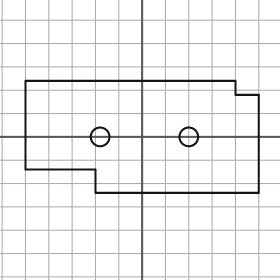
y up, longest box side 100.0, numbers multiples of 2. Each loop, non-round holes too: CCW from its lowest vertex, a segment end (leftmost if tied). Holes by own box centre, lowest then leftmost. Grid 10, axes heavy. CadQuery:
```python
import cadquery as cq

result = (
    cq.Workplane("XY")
    .moveTo(-20.0, -24.0)
    .lineTo(50.0, -24.0)
    .lineTo(50.0, 18.0)
    .lineTo(40.0, 18.0)
    .lineTo(40.0, 24.0)
    .lineTo(-50.0, 24.0)
    .lineTo(-50.0, -14.0)
    .lineTo(-20.0, -14.0)
    .close()
    .moveTo(-18.0, 0.0)
    .circle(4.0)
    .moveTo(20.0, 0.0)
    .circle(4.0)
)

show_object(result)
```